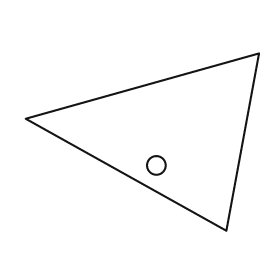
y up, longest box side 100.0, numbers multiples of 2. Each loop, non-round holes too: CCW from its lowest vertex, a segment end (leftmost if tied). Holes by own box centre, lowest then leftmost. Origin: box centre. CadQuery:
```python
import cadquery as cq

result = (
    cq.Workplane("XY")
    .moveTo(36.0, -38.0)
    .lineTo(50.0, 38.0)
    .lineTo(-50.0, 10.0)
    .close()
    .moveTo(6.0, -10.0)
    .circle(4.0)
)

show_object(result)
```